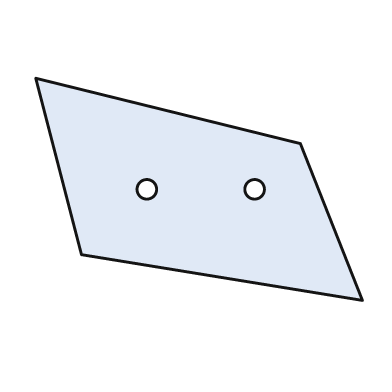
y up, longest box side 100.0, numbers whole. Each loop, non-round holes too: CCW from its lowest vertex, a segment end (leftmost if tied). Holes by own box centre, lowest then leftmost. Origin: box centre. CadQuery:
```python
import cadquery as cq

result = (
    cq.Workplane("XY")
    .moveTo(50.0, -34.0)
    .lineTo(31.0, 14.0)
    .lineTo(-50.0, 34.0)
    .lineTo(-36.0, -20.0)
    .close()
    .moveTo(-16.0, 0.0)
    .circle(3.0)
    .moveTo(17.0, 0.0)
    .circle(3.0)
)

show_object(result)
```